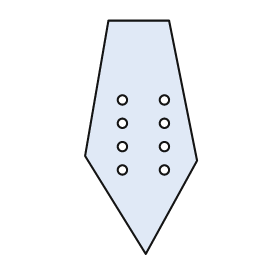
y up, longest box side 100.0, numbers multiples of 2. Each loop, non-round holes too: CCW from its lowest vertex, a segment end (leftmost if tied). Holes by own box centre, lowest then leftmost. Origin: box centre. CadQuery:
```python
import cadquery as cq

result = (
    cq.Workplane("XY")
    .moveTo(2.0, -50.0)
    .lineTo(24.0, -10.0)
    .lineTo(12.0, 50.0)
    .lineTo(-14.0, 50.0)
    .lineTo(-24.0, -8.0)
    .close()
    .moveTo(-8.0, -14.0)
    .circle(2.0)
    .moveTo(10.0, -14.0)
    .circle(2.0)
    .moveTo(-8.0, -4.0)
    .circle(2.0)
    .moveTo(10.0, -4.0)
    .circle(2.0)
    .moveTo(-8.0, 6.0)
    .circle(2.0)
    .moveTo(10.0, 6.0)
    .circle(2.0)
    .moveTo(-8.0, 16.0)
    .circle(2.0)
    .moveTo(10.0, 16.0)
    .circle(2.0)
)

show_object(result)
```